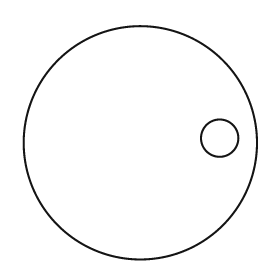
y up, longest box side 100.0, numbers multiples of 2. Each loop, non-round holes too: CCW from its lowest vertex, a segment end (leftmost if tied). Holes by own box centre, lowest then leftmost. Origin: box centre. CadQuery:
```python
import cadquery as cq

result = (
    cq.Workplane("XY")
    .moveTo(0.0, 0.0)
    .circle(50.0)
    .moveTo(34.0, 2.0)
    .circle(8.0)
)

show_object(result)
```